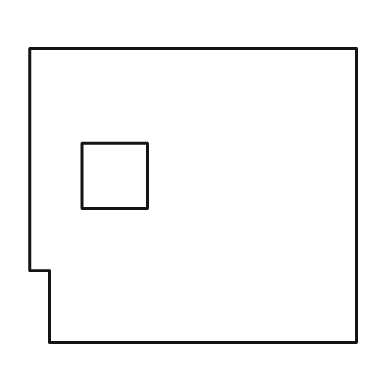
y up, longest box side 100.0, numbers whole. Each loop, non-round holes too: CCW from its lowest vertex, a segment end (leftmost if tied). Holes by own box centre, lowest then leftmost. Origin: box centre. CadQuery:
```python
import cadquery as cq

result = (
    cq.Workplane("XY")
    .moveTo(-44.0, -45.0)
    .lineTo(50.0, -45.0)
    .lineTo(50.0, 45.0)
    .lineTo(-50.0, 45.0)
    .lineTo(-50.0, -23.0)
    .lineTo(-44.0, -23.0)
    .close()
    .moveTo(-34.0, -4.0)
    .lineTo(-14.0, -4.0)
    .lineTo(-14.0, 16.0)
    .lineTo(-34.0, 16.0)
    .close()
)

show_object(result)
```